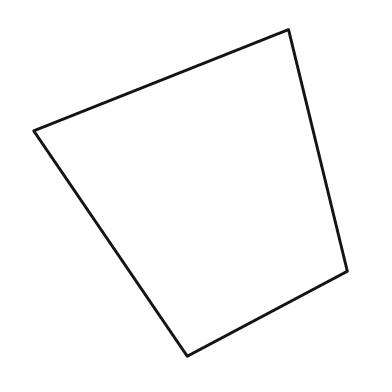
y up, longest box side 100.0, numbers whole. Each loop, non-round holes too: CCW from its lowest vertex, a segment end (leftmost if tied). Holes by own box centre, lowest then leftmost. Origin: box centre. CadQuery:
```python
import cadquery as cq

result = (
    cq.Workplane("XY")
    .moveTo(-1.0, -50.0)
    .lineTo(48.0, -24.0)
    .lineTo(30.0, 50.0)
    .lineTo(-48.0, 19.0)
    .close()
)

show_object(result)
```